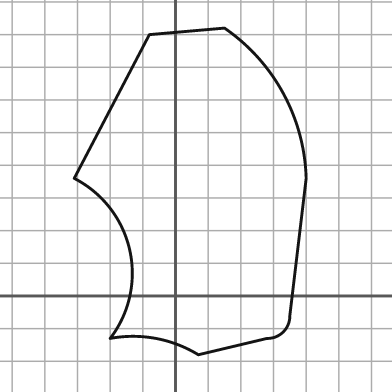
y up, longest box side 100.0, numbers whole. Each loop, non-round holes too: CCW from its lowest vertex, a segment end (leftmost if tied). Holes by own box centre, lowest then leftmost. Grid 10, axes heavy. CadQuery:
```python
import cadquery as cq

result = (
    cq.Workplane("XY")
    .moveTo(7.0, -18.0)
    .lineTo(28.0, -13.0)
    .threePointArc((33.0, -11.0), (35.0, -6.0))
    .lineTo(40.0, 36.0)
    .threePointArc((33.0, 62.0), (15.0, 82.0))
    .lineTo(-8.0, 80.0)
    .lineTo(-31.0, 36.0)
    .threePointArc((-14.0, 14.0), (-20.0, -13.0))
    .threePointArc((-6.0, -13.0), (7.0, -18.0))
    .close()
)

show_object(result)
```